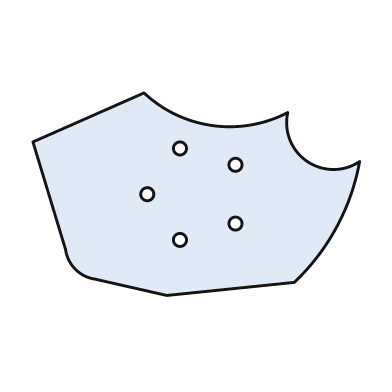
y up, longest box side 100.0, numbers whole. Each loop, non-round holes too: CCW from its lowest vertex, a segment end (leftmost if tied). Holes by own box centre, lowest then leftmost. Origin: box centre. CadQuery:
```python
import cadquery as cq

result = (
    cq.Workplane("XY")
    .moveTo(-9.0, -31.0)
    .lineTo(30.0, -27.0)
    .threePointArc((43.0, -10.0), (50.0, 10.0))
    .threePointArc((34.0, 10.0), (28.0, 25.0))
    .threePointArc((5.0, 21.0), (-16.0, 31.0))
    .lineTo(-50.0, 16.0)
    .lineTo(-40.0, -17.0)
    .threePointArc((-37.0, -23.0), (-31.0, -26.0))
    .close()
    .moveTo(-5.0, -14.0)
    .circle(2.0)
    .moveTo(12.0, -9.0)
    .circle(2.0)
    .moveTo(-15.0, 0.0)
    .circle(2.0)
    .moveTo(12.0, 9.0)
    .circle(2.0)
    .moveTo(-5.0, 14.0)
    .circle(2.0)
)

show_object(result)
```